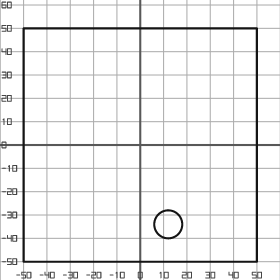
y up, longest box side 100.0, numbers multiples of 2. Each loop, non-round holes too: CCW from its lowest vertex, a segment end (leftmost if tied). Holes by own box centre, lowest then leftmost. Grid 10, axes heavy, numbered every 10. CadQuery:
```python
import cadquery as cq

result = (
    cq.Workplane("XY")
    .moveTo(-50.0, -50.0)
    .lineTo(50.0, -50.0)
    .lineTo(50.0, 50.0)
    .lineTo(-50.0, 50.0)
    .close()
    .moveTo(12.0, -34.0)
    .circle(6.0)
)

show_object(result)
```